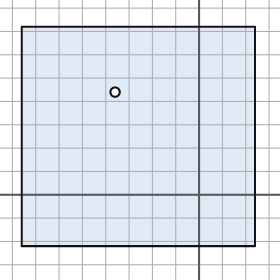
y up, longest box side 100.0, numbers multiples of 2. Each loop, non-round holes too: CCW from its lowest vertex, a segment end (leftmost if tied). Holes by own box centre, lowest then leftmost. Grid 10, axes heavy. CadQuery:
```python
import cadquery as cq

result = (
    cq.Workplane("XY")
    .moveTo(-76.0, -22.0)
    .lineTo(24.0, -22.0)
    .lineTo(24.0, 72.0)
    .lineTo(-76.0, 72.0)
    .close()
    .moveTo(-36.0, 44.0)
    .circle(2.0)
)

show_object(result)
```